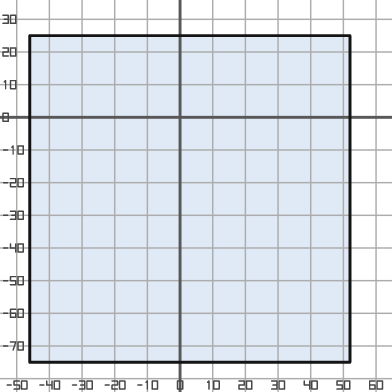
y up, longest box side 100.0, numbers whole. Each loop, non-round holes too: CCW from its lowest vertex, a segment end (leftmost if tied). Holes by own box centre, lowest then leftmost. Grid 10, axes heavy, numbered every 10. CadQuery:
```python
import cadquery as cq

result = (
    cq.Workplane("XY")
    .moveTo(-46.0, -75.0)
    .lineTo(52.0, -75.0)
    .lineTo(52.0, 25.0)
    .lineTo(-46.0, 25.0)
    .close()
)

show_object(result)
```